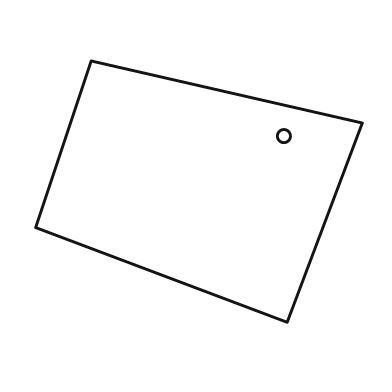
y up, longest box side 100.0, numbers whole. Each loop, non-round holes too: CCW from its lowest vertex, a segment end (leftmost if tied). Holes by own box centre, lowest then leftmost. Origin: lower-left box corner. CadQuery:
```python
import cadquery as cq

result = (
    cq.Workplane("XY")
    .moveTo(77.0, 0.0)
    .lineTo(100.0, 61.0)
    .lineTo(17.0, 80.0)
    .lineTo(0.0, 29.0)
    .close()
    .moveTo(76.0, 57.0)
    .circle(2.0)
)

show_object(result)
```